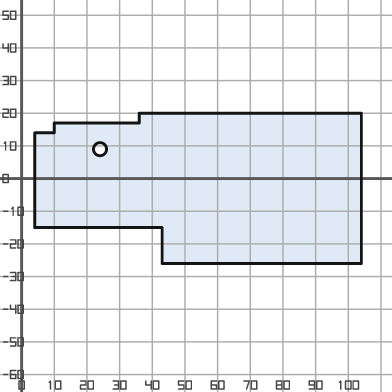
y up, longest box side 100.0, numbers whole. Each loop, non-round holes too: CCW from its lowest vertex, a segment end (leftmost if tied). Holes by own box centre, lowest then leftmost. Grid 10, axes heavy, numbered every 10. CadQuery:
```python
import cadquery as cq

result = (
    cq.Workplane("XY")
    .moveTo(43.0, -26.0)
    .lineTo(104.0, -26.0)
    .lineTo(104.0, 20.0)
    .lineTo(36.0, 20.0)
    .lineTo(36.0, 17.0)
    .lineTo(10.0, 17.0)
    .lineTo(10.0, 14.0)
    .lineTo(4.0, 14.0)
    .lineTo(4.0, -15.0)
    .lineTo(43.0, -15.0)
    .close()
    .moveTo(24.0, 9.0)
    .circle(2.0)
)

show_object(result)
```